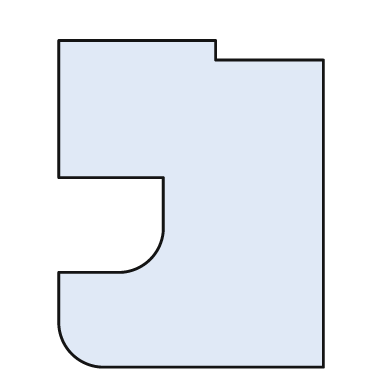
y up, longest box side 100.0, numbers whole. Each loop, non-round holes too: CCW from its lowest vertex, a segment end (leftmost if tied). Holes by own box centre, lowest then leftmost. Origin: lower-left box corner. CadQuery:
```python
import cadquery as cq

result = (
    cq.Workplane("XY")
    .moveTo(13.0, 0.0)
    .lineTo(81.0, 0.0)
    .lineTo(81.0, 94.0)
    .lineTo(48.0, 94.0)
    .lineTo(48.0, 100.0)
    .lineTo(0.0, 100.0)
    .lineTo(0.0, 58.0)
    .lineTo(32.0, 58.0)
    .lineTo(32.0, 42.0)
    .threePointArc((28.0, 33.0), (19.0, 29.0))
    .lineTo(0.0, 29.0)
    .lineTo(0.0, 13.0)
    .threePointArc((4.0, 4.0), (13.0, 0.0))
    .close()
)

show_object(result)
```